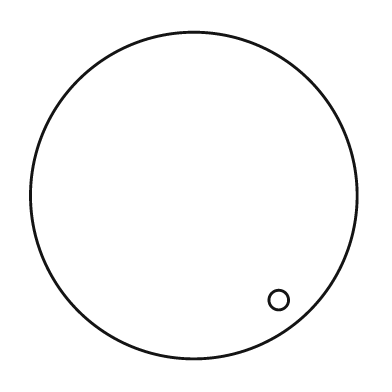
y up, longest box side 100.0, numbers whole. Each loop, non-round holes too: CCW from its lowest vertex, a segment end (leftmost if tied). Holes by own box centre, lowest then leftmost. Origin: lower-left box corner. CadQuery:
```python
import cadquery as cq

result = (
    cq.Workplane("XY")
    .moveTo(50.0, 50.0)
    .circle(50.0)
    .moveTo(76.0, 18.0)
    .circle(3.0)
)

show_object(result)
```